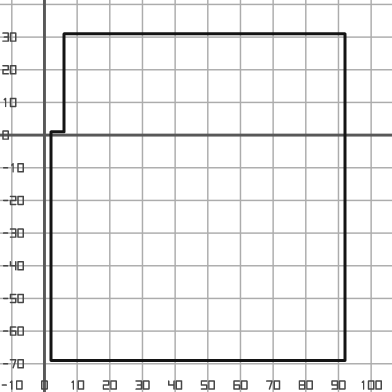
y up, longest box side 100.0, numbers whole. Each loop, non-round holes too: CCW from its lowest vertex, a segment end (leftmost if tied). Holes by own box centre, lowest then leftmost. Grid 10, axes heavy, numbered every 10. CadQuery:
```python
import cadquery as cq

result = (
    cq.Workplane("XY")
    .moveTo(2.0, -69.0)
    .lineTo(92.0, -69.0)
    .lineTo(92.0, 31.0)
    .lineTo(6.0, 31.0)
    .lineTo(6.0, 1.0)
    .lineTo(2.0, 1.0)
    .close()
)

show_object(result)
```